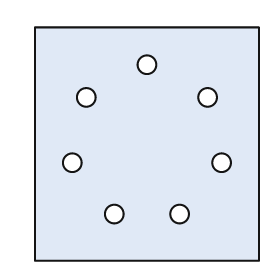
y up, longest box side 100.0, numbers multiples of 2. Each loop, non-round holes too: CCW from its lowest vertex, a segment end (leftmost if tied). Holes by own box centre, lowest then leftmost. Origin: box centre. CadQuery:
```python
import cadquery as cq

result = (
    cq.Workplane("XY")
    .moveTo(-48.0, -50.0)
    .lineTo(48.0, -50.0)
    .lineTo(48.0, 50.0)
    .lineTo(-48.0, 50.0)
    .close()
    .moveTo(-14.0, -30.0)
    .circle(4.0)
    .moveTo(14.0, -30.0)
    .circle(4.0)
    .moveTo(-32.0, -8.0)
    .circle(4.0)
    .moveTo(32.0, -8.0)
    .circle(4.0)
    .moveTo(-26.0, 20.0)
    .circle(4.0)
    .moveTo(26.0, 20.0)
    .circle(4.0)
    .moveTo(0.0, 34.0)
    .circle(4.0)
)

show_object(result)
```